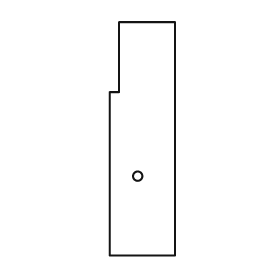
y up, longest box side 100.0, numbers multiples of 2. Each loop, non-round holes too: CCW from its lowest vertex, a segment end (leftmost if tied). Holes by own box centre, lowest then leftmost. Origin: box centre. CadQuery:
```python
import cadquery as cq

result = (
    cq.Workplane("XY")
    .moveTo(-14.0, -50.0)
    .lineTo(14.0, -50.0)
    .lineTo(14.0, 50.0)
    .lineTo(-10.0, 50.0)
    .lineTo(-10.0, 20.0)
    .lineTo(-14.0, 20.0)
    .close()
    .moveTo(-2.0, -16.0)
    .circle(2.0)
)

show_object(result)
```